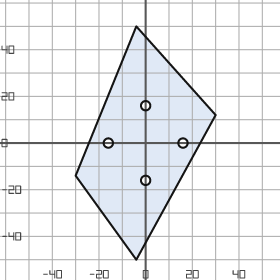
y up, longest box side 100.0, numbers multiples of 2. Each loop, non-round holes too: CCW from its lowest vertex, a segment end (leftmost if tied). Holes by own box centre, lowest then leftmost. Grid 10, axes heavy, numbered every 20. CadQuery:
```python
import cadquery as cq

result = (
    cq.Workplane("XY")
    .moveTo(-4.0, -50.0)
    .lineTo(30.0, 12.0)
    .lineTo(-4.0, 50.0)
    .lineTo(-30.0, -14.0)
    .close()
    .moveTo(0.0, -16.0)
    .circle(2.0)
    .moveTo(-16.0, 0.0)
    .circle(2.0)
    .moveTo(16.0, 0.0)
    .circle(2.0)
    .moveTo(0.0, 16.0)
    .circle(2.0)
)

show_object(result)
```